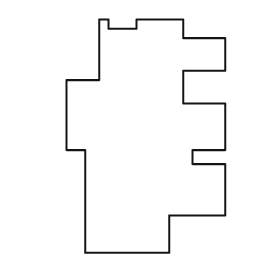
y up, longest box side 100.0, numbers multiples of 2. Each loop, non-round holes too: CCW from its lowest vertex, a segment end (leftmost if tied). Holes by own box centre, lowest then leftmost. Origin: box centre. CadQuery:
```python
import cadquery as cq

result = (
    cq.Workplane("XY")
    .moveTo(-26.0, -50.0)
    .lineTo(10.0, -50.0)
    .lineTo(10.0, -34.0)
    .lineTo(34.0, -34.0)
    .lineTo(34.0, -12.0)
    .lineTo(20.0, -12.0)
    .lineTo(20.0, -6.0)
    .lineTo(34.0, -6.0)
    .lineTo(34.0, 14.0)
    .lineTo(16.0, 14.0)
    .lineTo(16.0, 28.0)
    .lineTo(34.0, 28.0)
    .lineTo(34.0, 42.0)
    .lineTo(16.0, 42.0)
    .lineTo(16.0, 50.0)
    .lineTo(-4.0, 50.0)
    .lineTo(-4.0, 46.0)
    .lineTo(-16.0, 46.0)
    .lineTo(-16.0, 50.0)
    .lineTo(-20.0, 50.0)
    .lineTo(-20.0, 24.0)
    .lineTo(-34.0, 24.0)
    .lineTo(-34.0, -6.0)
    .lineTo(-26.0, -6.0)
    .close()
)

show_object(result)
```